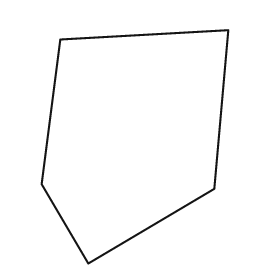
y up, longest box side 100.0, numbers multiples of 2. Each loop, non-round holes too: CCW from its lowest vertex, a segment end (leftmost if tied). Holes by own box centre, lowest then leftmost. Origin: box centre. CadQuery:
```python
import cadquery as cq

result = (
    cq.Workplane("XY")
    .moveTo(-20.0, -50.0)
    .lineTo(34.0, -18.0)
    .lineTo(40.0, 50.0)
    .lineTo(-32.0, 46.0)
    .lineTo(-40.0, -16.0)
    .close()
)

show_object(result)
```